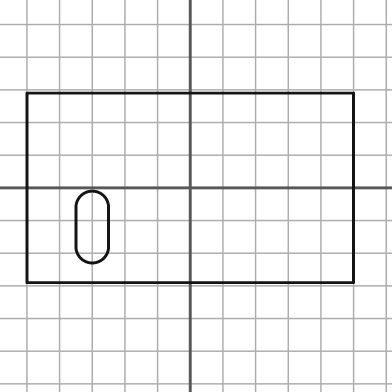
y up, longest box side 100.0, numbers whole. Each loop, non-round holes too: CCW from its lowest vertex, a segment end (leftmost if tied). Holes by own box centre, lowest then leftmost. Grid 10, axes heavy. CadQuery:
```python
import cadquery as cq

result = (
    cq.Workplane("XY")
    .moveTo(-50.0, -29.0)
    .lineTo(50.0, -29.0)
    .lineTo(50.0, 29.0)
    .lineTo(-50.0, 29.0)
    .close()
    .moveTo(-35.0, -18.0)
    .threePointArc((-30.0, -23.0), (-25.0, -18.0))
    .lineTo(-25.0, -6.0)
    .threePointArc((-30.0, -1.0), (-35.0, -6.0))
    .close()
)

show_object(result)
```